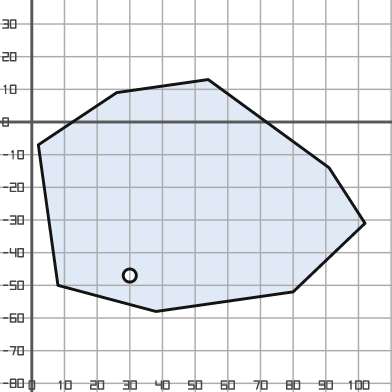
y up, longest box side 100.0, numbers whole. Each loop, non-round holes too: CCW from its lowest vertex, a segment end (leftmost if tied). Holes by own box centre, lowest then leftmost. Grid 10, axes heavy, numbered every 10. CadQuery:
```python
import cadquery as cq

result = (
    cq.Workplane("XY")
    .moveTo(38.0, -58.0)
    .lineTo(80.0, -52.0)
    .lineTo(102.0, -31.0)
    .lineTo(91.0, -14.0)
    .lineTo(54.0, 13.0)
    .lineTo(26.0, 9.0)
    .lineTo(2.0, -7.0)
    .lineTo(8.0, -50.0)
    .close()
    .moveTo(30.0, -47.0)
    .circle(2.0)
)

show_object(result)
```